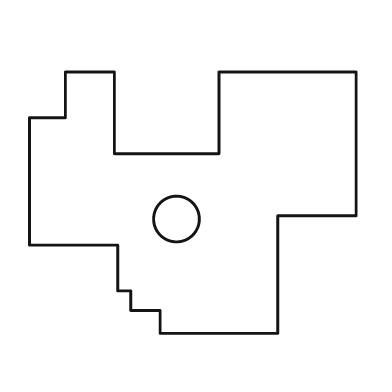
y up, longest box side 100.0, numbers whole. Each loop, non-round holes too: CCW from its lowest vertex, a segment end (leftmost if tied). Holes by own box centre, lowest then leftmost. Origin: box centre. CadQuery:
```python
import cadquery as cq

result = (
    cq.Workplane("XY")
    .moveTo(-10.0, -40.0)
    .lineTo(26.0, -40.0)
    .lineTo(26.0, -4.0)
    .lineTo(50.0, -4.0)
    .lineTo(50.0, 40.0)
    .lineTo(8.0, 40.0)
    .lineTo(8.0, 15.0)
    .lineTo(-24.0, 15.0)
    .lineTo(-24.0, 40.0)
    .lineTo(-39.0, 40.0)
    .lineTo(-39.0, 26.0)
    .lineTo(-50.0, 26.0)
    .lineTo(-50.0, -13.0)
    .lineTo(-23.0, -13.0)
    .lineTo(-23.0, -27.0)
    .lineTo(-19.0, -27.0)
    .lineTo(-19.0, -33.0)
    .lineTo(-10.0, -33.0)
    .close()
    .moveTo(-5.0, -5.0)
    .circle(7.0)
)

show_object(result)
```